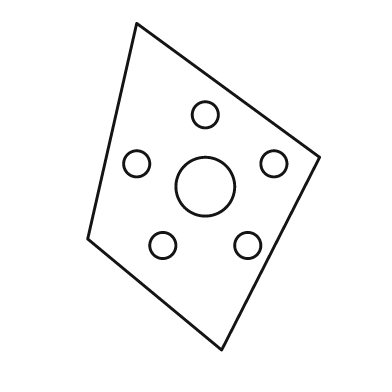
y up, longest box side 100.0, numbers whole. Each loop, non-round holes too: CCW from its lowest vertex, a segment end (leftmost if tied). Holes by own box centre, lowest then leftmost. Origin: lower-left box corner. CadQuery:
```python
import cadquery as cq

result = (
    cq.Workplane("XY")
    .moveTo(41.0, 0.0)
    .lineTo(71.0, 59.0)
    .lineTo(15.0, 100.0)
    .lineTo(0.0, 34.0)
    .close()
    .moveTo(23.0, 32.0)
    .circle(4.0)
    .moveTo(49.0, 32.0)
    .circle(4.0)
    .moveTo(36.0, 50.0)
    .circle(9.0)
    .moveTo(15.0, 57.0)
    .circle(4.0)
    .moveTo(57.0, 57.0)
    .circle(4.0)
    .moveTo(36.0, 72.0)
    .circle(4.0)
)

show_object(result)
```